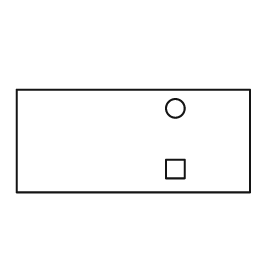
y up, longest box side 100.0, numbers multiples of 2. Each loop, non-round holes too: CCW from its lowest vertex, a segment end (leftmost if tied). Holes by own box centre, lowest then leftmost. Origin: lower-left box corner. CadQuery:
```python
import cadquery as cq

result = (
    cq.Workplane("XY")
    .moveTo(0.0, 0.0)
    .lineTo(100.0, 0.0)
    .lineTo(100.0, 44.0)
    .lineTo(0.0, 44.0)
    .close()
    .moveTo(64.0, 6.0)
    .lineTo(72.0, 6.0)
    .lineTo(72.0, 14.0)
    .lineTo(64.0, 14.0)
    .close()
    .moveTo(68.0, 36.0)
    .circle(4.0)
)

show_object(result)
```